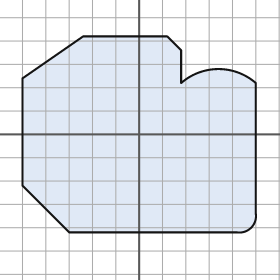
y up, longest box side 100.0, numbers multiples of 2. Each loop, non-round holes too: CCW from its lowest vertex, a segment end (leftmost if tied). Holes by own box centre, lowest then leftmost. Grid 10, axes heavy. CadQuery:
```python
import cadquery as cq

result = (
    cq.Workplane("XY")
    .moveTo(-30.0, -42.0)
    .lineTo(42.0, -42.0)
    .threePointArc((48.0, -40.0), (50.0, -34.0))
    .lineTo(50.0, 22.0)
    .threePointArc((34.0, 28.0), (18.0, 22.0))
    .lineTo(18.0, 36.0)
    .lineTo(12.0, 42.0)
    .lineTo(-24.0, 42.0)
    .lineTo(-50.0, 24.0)
    .lineTo(-50.0, -22.0)
    .close()
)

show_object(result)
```